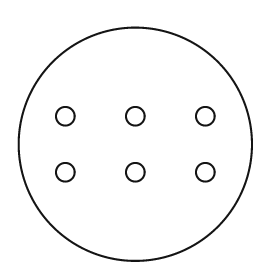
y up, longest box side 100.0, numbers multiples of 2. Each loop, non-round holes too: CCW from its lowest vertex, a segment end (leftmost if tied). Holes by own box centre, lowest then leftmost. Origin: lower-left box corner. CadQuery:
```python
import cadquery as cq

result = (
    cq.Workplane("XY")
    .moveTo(50.0, 50.0)
    .circle(50.0)
    .moveTo(20.0, 38.0)
    .circle(4.0)
    .moveTo(50.0, 38.0)
    .circle(4.0)
    .moveTo(80.0, 38.0)
    .circle(4.0)
    .moveTo(20.0, 62.0)
    .circle(4.0)
    .moveTo(50.0, 62.0)
    .circle(4.0)
    .moveTo(80.0, 62.0)
    .circle(4.0)
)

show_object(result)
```